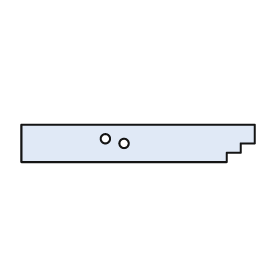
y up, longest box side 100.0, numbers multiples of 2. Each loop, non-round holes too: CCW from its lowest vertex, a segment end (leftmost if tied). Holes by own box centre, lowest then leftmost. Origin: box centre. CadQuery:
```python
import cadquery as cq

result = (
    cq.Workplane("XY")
    .moveTo(-50.0, -8.0)
    .lineTo(38.0, -8.0)
    .lineTo(38.0, -4.0)
    .lineTo(44.0, -4.0)
    .lineTo(44.0, 0.0)
    .lineTo(50.0, 0.0)
    .lineTo(50.0, 8.0)
    .lineTo(-50.0, 8.0)
    .close()
    .moveTo(-6.0, 0.0)
    .circle(2.0)
    .moveTo(-14.0, 2.0)
    .circle(2.0)
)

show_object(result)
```